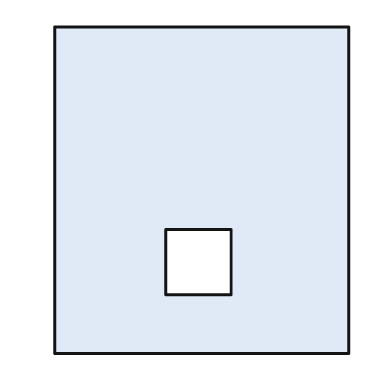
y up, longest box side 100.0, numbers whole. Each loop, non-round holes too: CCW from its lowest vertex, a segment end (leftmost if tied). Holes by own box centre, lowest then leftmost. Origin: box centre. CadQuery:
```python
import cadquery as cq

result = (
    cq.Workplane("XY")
    .moveTo(-45.0, -50.0)
    .lineTo(45.0, -50.0)
    .lineTo(45.0, 50.0)
    .lineTo(-45.0, 50.0)
    .close()
    .moveTo(-11.0, -32.0)
    .lineTo(9.0, -32.0)
    .lineTo(9.0, -12.0)
    .lineTo(-11.0, -12.0)
    .close()
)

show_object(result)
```